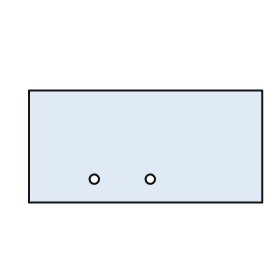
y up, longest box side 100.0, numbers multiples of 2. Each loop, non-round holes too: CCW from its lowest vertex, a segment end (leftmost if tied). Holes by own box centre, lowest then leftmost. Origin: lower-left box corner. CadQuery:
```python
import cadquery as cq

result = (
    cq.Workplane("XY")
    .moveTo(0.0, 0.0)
    .lineTo(100.0, 0.0)
    .lineTo(100.0, 48.0)
    .lineTo(0.0, 48.0)
    .close()
    .moveTo(28.0, 10.0)
    .circle(2.0)
    .moveTo(52.0, 10.0)
    .circle(2.0)
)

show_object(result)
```